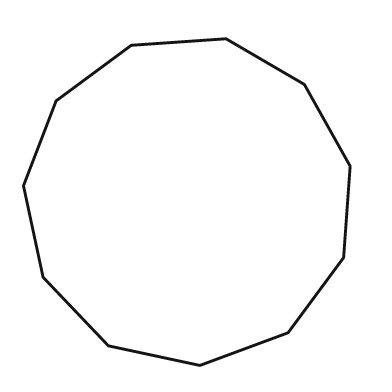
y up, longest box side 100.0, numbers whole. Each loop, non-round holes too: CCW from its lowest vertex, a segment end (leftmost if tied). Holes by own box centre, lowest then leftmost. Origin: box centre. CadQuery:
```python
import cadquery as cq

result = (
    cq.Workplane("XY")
    .moveTo(4.0, -50.0)
    .lineTo(31.0, -40.0)
    .lineTo(48.0, -17.0)
    .lineTo(50.0, 11.0)
    .lineTo(36.0, 36.0)
    .lineTo(12.0, 50.0)
    .lineTo(-17.0, 48.0)
    .lineTo(-40.0, 31.0)
    .lineTo(-50.0, 5.0)
    .lineTo(-44.0, -23.0)
    .lineTo(-24.0, -44.0)
    .close()
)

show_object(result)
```